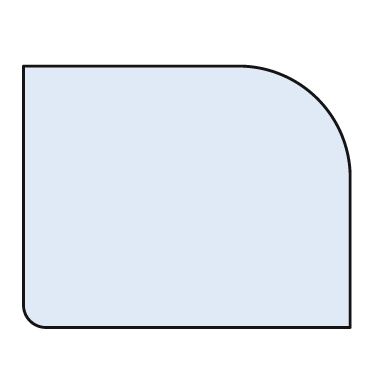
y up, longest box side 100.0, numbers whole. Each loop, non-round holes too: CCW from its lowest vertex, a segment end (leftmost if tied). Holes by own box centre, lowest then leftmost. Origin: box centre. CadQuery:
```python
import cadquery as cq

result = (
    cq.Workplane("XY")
    .moveTo(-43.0, -40.0)
    .lineTo(50.0, -40.0)
    .lineTo(50.0, 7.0)
    .threePointArc((40.0, 30.0), (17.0, 40.0))
    .lineTo(-50.0, 40.0)
    .lineTo(-50.0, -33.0)
    .threePointArc((-48.0, -38.0), (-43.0, -40.0))
    .close()
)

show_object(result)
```